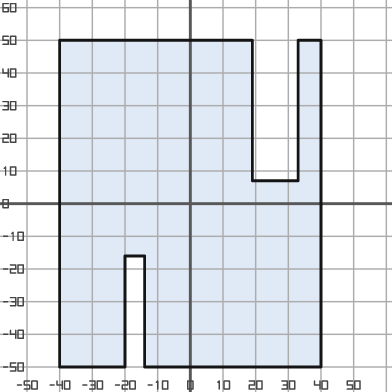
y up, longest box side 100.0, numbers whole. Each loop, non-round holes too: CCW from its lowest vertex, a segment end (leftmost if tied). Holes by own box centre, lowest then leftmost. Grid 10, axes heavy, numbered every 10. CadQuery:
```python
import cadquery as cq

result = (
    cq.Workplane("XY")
    .moveTo(-40.0, -50.0)
    .lineTo(-20.0, -50.0)
    .lineTo(-20.0, -16.0)
    .lineTo(-14.0, -16.0)
    .lineTo(-14.0, -50.0)
    .lineTo(40.0, -50.0)
    .lineTo(40.0, 50.0)
    .lineTo(33.0, 50.0)
    .lineTo(33.0, 7.0)
    .lineTo(19.0, 7.0)
    .lineTo(19.0, 50.0)
    .lineTo(-40.0, 50.0)
    .close()
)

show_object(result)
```